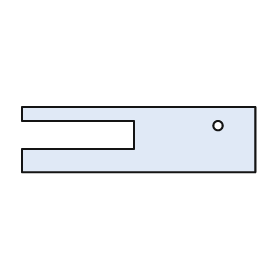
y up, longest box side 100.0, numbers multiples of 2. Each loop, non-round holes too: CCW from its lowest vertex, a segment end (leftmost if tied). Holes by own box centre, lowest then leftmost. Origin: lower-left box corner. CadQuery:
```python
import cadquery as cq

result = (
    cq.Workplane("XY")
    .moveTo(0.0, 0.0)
    .lineTo(100.0, 0.0)
    .lineTo(100.0, 28.0)
    .lineTo(0.0, 28.0)
    .lineTo(0.0, 22.0)
    .lineTo(48.0, 22.0)
    .lineTo(48.0, 10.0)
    .lineTo(0.0, 10.0)
    .close()
    .moveTo(84.0, 20.0)
    .circle(2.0)
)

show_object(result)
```